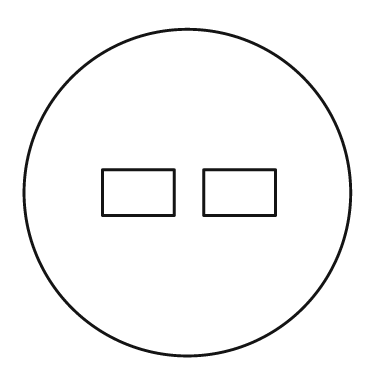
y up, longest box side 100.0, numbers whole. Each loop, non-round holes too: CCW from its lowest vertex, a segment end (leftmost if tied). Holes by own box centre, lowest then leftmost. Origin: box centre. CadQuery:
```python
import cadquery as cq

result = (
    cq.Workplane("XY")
    .moveTo(0.0, 0.0)
    .circle(50.0)
    .moveTo(-26.0, -7.0)
    .lineTo(-4.0, -7.0)
    .lineTo(-4.0, 7.0)
    .lineTo(-26.0, 7.0)
    .close()
    .moveTo(5.0, -7.0)
    .lineTo(27.0, -7.0)
    .lineTo(27.0, 7.0)
    .lineTo(5.0, 7.0)
    .close()
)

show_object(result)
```